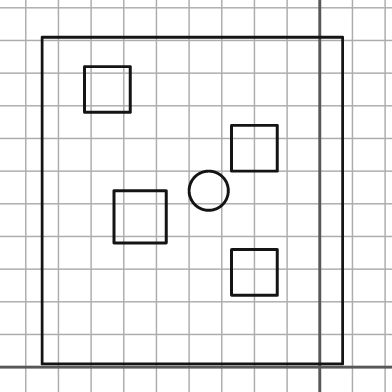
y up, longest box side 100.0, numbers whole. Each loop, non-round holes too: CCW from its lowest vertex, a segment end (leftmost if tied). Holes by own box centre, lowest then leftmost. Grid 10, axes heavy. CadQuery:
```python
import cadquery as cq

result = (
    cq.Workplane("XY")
    .moveTo(-85.0, 1.0)
    .lineTo(7.0, 1.0)
    .lineTo(7.0, 101.0)
    .lineTo(-85.0, 101.0)
    .close()
    .moveTo(-27.0, 22.0)
    .lineTo(-13.0, 22.0)
    .lineTo(-13.0, 36.0)
    .lineTo(-27.0, 36.0)
    .close()
    .moveTo(-63.0, 38.0)
    .lineTo(-47.0, 38.0)
    .lineTo(-47.0, 54.0)
    .lineTo(-63.0, 54.0)
    .close()
    .moveTo(-34.0, 54.0)
    .circle(6.0)
    .moveTo(-27.0, 60.0)
    .lineTo(-13.0, 60.0)
    .lineTo(-13.0, 74.0)
    .lineTo(-27.0, 74.0)
    .close()
    .moveTo(-72.0, 78.0)
    .lineTo(-58.0, 78.0)
    .lineTo(-58.0, 92.0)
    .lineTo(-72.0, 92.0)
    .close()
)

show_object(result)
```